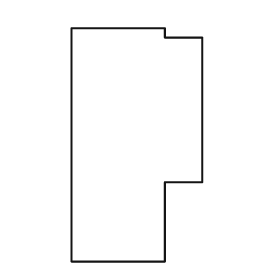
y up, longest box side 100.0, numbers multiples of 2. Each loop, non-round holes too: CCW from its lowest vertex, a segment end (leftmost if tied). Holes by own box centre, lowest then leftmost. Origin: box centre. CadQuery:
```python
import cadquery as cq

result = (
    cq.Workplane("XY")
    .moveTo(-28.0, -50.0)
    .lineTo(12.0, -50.0)
    .lineTo(12.0, -16.0)
    .lineTo(28.0, -16.0)
    .lineTo(28.0, 46.0)
    .lineTo(12.0, 46.0)
    .lineTo(12.0, 50.0)
    .lineTo(-28.0, 50.0)
    .close()
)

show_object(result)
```